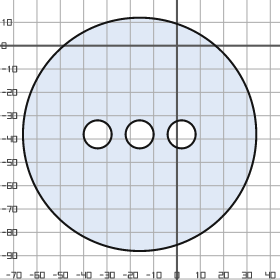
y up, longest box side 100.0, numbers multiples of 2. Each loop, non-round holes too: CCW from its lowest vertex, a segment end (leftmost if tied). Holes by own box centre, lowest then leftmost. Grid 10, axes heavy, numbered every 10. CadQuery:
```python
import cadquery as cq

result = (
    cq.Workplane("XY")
    .moveTo(-16.0, -38.0)
    .circle(50.0)
    .moveTo(-34.0, -38.0)
    .circle(6.0)
    .moveTo(-16.0, -38.0)
    .circle(6.0)
    .moveTo(2.0, -38.0)
    .circle(6.0)
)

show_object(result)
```